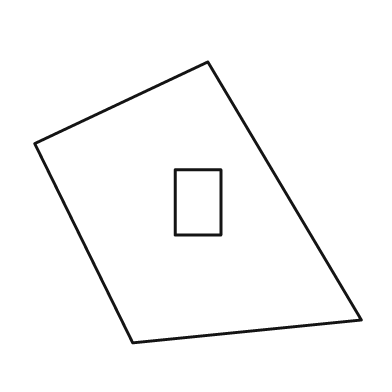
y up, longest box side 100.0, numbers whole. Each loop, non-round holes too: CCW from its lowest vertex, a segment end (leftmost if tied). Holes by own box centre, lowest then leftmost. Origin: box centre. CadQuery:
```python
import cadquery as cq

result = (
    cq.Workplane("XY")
    .moveTo(-20.0, -43.0)
    .lineTo(50.0, -36.0)
    .lineTo(3.0, 43.0)
    .lineTo(-50.0, 18.0)
    .close()
    .moveTo(-7.0, -10.0)
    .lineTo(7.0, -10.0)
    .lineTo(7.0, 10.0)
    .lineTo(-7.0, 10.0)
    .close()
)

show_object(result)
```